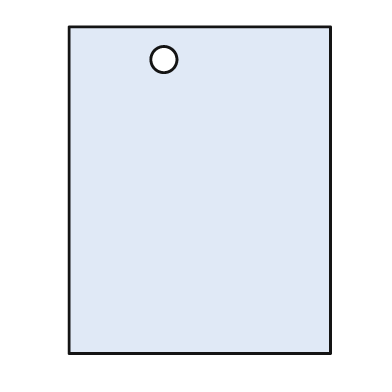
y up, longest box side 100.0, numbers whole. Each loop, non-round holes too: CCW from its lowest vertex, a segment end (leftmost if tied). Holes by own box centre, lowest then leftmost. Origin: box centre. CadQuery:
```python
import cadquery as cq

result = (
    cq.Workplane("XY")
    .moveTo(-40.0, -50.0)
    .lineTo(40.0, -50.0)
    .lineTo(40.0, 50.0)
    .lineTo(-40.0, 50.0)
    .close()
    .moveTo(-11.0, 40.0)
    .circle(4.0)
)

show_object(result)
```